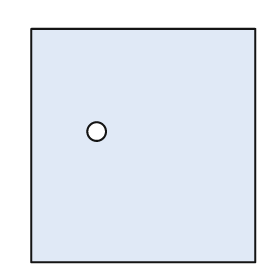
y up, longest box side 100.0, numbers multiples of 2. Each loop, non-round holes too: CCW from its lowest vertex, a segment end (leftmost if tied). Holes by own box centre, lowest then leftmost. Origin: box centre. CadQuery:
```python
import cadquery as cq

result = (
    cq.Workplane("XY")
    .moveTo(-48.0, -50.0)
    .lineTo(48.0, -50.0)
    .lineTo(48.0, 50.0)
    .lineTo(-48.0, 50.0)
    .close()
    .moveTo(-20.0, 6.0)
    .circle(4.0)
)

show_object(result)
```